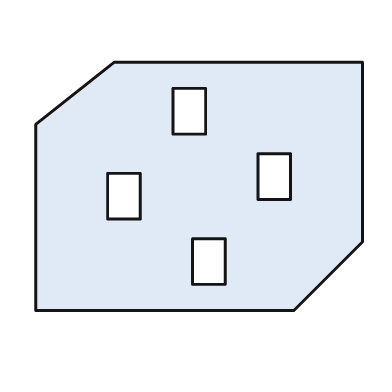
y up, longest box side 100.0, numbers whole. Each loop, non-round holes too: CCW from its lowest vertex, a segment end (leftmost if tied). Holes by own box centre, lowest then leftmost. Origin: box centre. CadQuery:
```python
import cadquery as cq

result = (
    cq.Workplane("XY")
    .moveTo(-50.0, -38.0)
    .lineTo(29.0, -38.0)
    .lineTo(50.0, -17.0)
    .lineTo(50.0, 38.0)
    .lineTo(-26.0, 38.0)
    .lineTo(-50.0, 19.0)
    .close()
    .moveTo(-2.0, -30.0)
    .lineTo(8.0, -30.0)
    .lineTo(8.0, -16.0)
    .lineTo(-2.0, -16.0)
    .close()
    .moveTo(-28.0, -10.0)
    .lineTo(-18.0, -10.0)
    .lineTo(-18.0, 4.0)
    .lineTo(-28.0, 4.0)
    .close()
    .moveTo(18.0, -4.0)
    .lineTo(28.0, -4.0)
    .lineTo(28.0, 10.0)
    .lineTo(18.0, 10.0)
    .close()
    .moveTo(-8.0, 16.0)
    .lineTo(2.0, 16.0)
    .lineTo(2.0, 30.0)
    .lineTo(-8.0, 30.0)
    .close()
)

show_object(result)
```